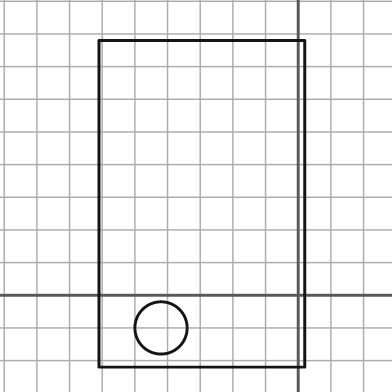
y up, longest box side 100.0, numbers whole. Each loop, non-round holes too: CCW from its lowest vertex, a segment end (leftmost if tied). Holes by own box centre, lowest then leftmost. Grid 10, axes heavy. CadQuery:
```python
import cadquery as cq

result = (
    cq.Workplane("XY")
    .moveTo(-61.0, -22.0)
    .lineTo(2.0, -22.0)
    .lineTo(2.0, 78.0)
    .lineTo(-61.0, 78.0)
    .close()
    .moveTo(-42.0, -10.0)
    .circle(8.0)
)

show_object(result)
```